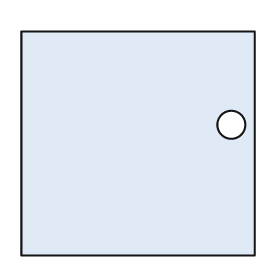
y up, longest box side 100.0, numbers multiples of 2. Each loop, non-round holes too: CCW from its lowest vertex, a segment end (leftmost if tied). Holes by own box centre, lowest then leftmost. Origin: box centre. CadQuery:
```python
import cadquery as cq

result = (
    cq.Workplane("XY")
    .moveTo(-50.0, -48.0)
    .lineTo(50.0, -48.0)
    .lineTo(50.0, 48.0)
    .lineTo(-50.0, 48.0)
    .close()
    .moveTo(40.0, 8.0)
    .circle(6.0)
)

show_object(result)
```